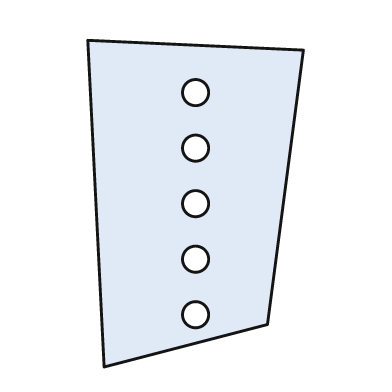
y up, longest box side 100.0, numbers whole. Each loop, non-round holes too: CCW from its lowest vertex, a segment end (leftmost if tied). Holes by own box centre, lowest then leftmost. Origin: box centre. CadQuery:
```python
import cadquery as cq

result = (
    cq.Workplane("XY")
    .moveTo(-28.0, -50.0)
    .lineTo(22.0, -37.0)
    .lineTo(33.0, 47.0)
    .lineTo(-33.0, 50.0)
    .close()
    .moveTo(0.0, -34.0)
    .circle(4.0)
    .moveTo(0.0, -17.0)
    .circle(4.0)
    .moveTo(0.0, 0.0)
    .circle(4.0)
    .moveTo(0.0, 17.0)
    .circle(4.0)
    .moveTo(0.0, 34.0)
    .circle(4.0)
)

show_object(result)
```